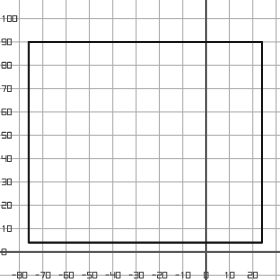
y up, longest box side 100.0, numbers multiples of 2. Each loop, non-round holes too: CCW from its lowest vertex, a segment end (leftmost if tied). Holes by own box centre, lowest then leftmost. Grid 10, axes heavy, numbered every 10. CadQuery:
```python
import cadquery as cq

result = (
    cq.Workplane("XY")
    .moveTo(-76.0, 4.0)
    .lineTo(24.0, 4.0)
    .lineTo(24.0, 90.0)
    .lineTo(-76.0, 90.0)
    .close()
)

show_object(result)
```